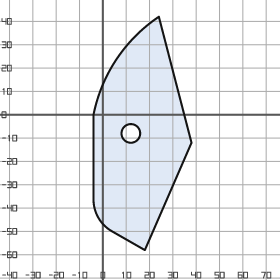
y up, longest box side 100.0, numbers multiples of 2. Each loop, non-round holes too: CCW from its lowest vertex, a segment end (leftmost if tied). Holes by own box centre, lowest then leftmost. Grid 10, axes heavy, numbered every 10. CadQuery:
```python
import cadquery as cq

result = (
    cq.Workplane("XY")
    .moveTo(18.0, -58.0)
    .lineTo(38.0, -12.0)
    .lineTo(24.0, 42.0)
    .threePointArc((6.0, 24.0), (-4.0, 0.0))
    .lineTo(-4.0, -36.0)
    .threePointArc((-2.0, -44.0), (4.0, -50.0))
    .close()
    .moveTo(12.0, -8.0)
    .circle(4.0)
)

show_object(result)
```